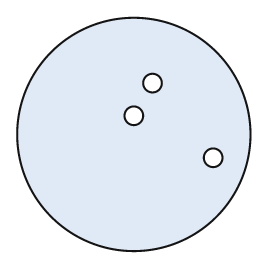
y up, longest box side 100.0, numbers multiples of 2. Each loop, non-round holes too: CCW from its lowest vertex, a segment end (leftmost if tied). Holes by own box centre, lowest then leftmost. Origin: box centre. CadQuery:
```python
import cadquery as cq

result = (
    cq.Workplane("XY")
    .moveTo(0.0, 0.0)
    .circle(50.0)
    .moveTo(34.0, -10.0)
    .circle(4.0)
    .moveTo(0.0, 8.0)
    .circle(4.0)
    .moveTo(8.0, 22.0)
    .circle(4.0)
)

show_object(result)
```